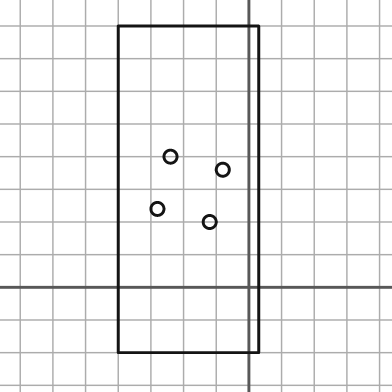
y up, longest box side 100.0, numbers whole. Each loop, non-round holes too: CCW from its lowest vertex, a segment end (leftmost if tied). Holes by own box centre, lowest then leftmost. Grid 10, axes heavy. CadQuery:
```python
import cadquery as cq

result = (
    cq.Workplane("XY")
    .moveTo(-40.0, -20.0)
    .lineTo(3.0, -20.0)
    .lineTo(3.0, 80.0)
    .lineTo(-40.0, 80.0)
    .close()
    .moveTo(-12.0, 20.0)
    .circle(2.0)
    .moveTo(-28.0, 24.0)
    .circle(2.0)
    .moveTo(-8.0, 36.0)
    .circle(2.0)
    .moveTo(-24.0, 40.0)
    .circle(2.0)
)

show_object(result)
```